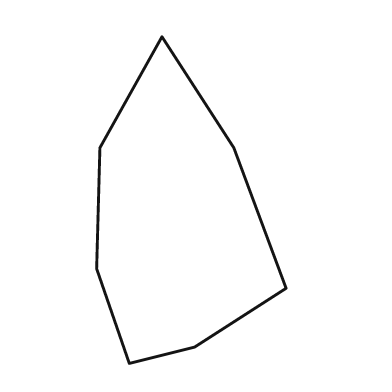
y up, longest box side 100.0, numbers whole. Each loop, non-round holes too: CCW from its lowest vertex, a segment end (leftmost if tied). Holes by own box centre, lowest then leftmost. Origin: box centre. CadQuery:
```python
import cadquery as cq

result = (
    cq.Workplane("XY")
    .moveTo(-19.0, -50.0)
    .lineTo(1.0, -45.0)
    .lineTo(29.0, -27.0)
    .lineTo(13.0, 16.0)
    .lineTo(-9.0, 50.0)
    .lineTo(-28.0, 16.0)
    .lineTo(-29.0, -21.0)
    .close()
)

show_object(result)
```